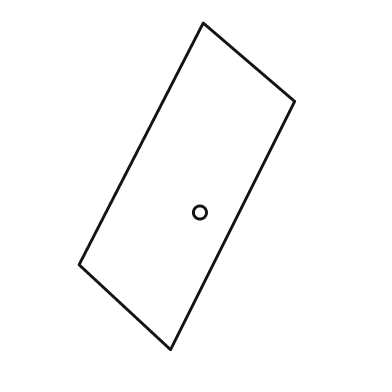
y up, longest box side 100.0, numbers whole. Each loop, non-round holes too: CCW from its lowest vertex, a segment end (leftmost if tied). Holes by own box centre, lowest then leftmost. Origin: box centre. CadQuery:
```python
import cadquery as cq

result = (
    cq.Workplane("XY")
    .moveTo(-5.0, -50.0)
    .lineTo(33.0, 26.0)
    .lineTo(5.0, 50.0)
    .lineTo(-33.0, -24.0)
    .close()
    .moveTo(4.0, -8.0)
    .circle(2.0)
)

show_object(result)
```